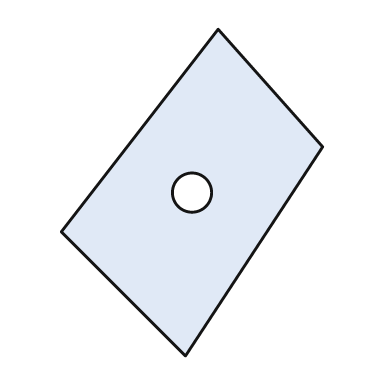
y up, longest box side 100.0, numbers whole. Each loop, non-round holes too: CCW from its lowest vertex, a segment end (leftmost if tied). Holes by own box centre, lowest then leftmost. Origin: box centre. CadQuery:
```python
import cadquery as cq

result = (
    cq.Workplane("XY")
    .moveTo(-2.0, -50.0)
    .lineTo(40.0, 14.0)
    .lineTo(8.0, 50.0)
    .lineTo(-40.0, -12.0)
    .close()
    .moveTo(0.0, 0.0)
    .circle(6.0)
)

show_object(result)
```